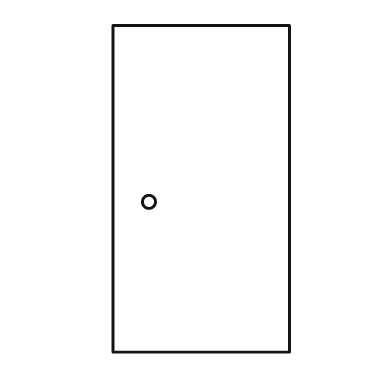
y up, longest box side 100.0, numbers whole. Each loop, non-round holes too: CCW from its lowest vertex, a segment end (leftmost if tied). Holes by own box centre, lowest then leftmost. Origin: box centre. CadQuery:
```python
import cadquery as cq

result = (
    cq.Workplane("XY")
    .moveTo(-27.0, -50.0)
    .lineTo(27.0, -50.0)
    .lineTo(27.0, 50.0)
    .lineTo(-27.0, 50.0)
    .close()
    .moveTo(-16.0, -4.0)
    .circle(2.0)
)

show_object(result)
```